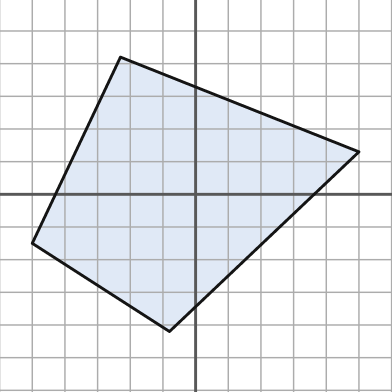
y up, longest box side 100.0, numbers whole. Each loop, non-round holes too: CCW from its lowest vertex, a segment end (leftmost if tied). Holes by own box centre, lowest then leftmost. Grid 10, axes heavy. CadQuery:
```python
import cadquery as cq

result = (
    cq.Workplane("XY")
    .moveTo(-8.0, -42.0)
    .lineTo(50.0, 13.0)
    .lineTo(-23.0, 42.0)
    .lineTo(-50.0, -15.0)
    .close()
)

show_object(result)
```